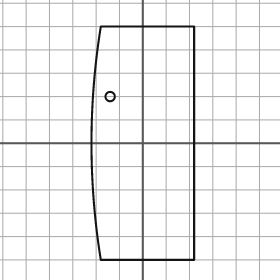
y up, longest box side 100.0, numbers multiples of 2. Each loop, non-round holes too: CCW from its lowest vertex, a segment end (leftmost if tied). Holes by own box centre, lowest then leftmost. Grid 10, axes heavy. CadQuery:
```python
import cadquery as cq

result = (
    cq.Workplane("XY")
    .moveTo(-18.0, -50.0)
    .lineTo(22.0, -50.0)
    .lineTo(22.0, 50.0)
    .lineTo(-18.0, 50.0)
    .threePointArc((-22.0, 0.0), (-18.0, -50.0))
    .close()
    .moveTo(-14.0, 20.0)
    .circle(2.0)
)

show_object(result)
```